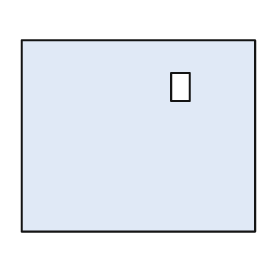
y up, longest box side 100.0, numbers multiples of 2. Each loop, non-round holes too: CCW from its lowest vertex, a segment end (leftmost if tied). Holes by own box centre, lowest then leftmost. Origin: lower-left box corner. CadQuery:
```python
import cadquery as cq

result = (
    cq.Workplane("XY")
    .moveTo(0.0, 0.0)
    .lineTo(100.0, 0.0)
    .lineTo(100.0, 82.0)
    .lineTo(0.0, 82.0)
    .close()
    .moveTo(64.0, 56.0)
    .lineTo(72.0, 56.0)
    .lineTo(72.0, 68.0)
    .lineTo(64.0, 68.0)
    .close()
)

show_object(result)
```